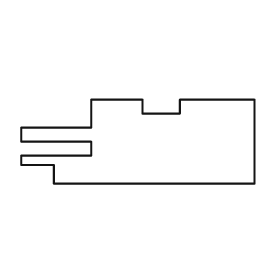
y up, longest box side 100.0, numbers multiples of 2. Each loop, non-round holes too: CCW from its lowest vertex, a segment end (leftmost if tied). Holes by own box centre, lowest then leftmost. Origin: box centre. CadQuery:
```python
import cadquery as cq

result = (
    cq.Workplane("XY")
    .moveTo(-36.0, -18.0)
    .lineTo(50.0, -18.0)
    .lineTo(50.0, 18.0)
    .lineTo(18.0, 18.0)
    .lineTo(18.0, 12.0)
    .lineTo(2.0, 12.0)
    .lineTo(2.0, 18.0)
    .lineTo(-20.0, 18.0)
    .lineTo(-20.0, 6.0)
    .lineTo(-50.0, 6.0)
    .lineTo(-50.0, 0.0)
    .lineTo(-20.0, 0.0)
    .lineTo(-20.0, -6.0)
    .lineTo(-50.0, -6.0)
    .lineTo(-50.0, -10.0)
    .lineTo(-36.0, -10.0)
    .close()
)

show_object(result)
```